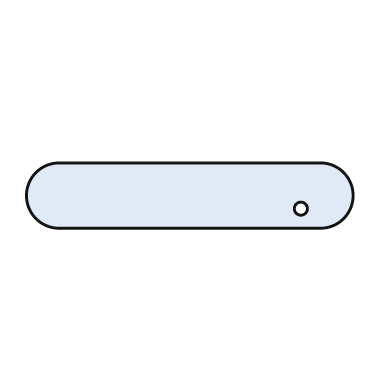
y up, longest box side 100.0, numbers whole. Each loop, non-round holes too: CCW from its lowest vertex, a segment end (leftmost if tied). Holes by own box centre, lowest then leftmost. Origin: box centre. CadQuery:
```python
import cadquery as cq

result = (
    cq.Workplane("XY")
    .moveTo(-40.0, -10.0)
    .lineTo(40.0, -10.0)
    .threePointArc((50.0, 0.0), (40.0, 10.0))
    .lineTo(-40.0, 10.0)
    .threePointArc((-50.0, 0.0), (-40.0, -10.0))
    .close()
    .moveTo(34.0, -4.0)
    .circle(2.0)
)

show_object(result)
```